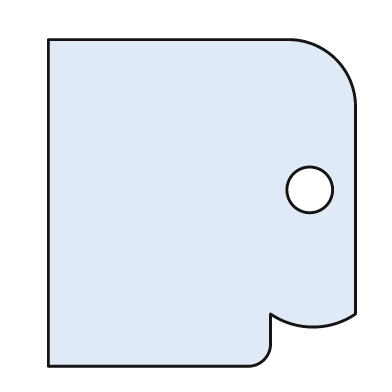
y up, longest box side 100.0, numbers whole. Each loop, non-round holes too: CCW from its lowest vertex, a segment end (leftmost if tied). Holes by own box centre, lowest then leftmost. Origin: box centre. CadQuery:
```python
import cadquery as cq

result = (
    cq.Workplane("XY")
    .moveTo(-47.0, -50.0)
    .lineTo(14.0, -50.0)
    .threePointArc((19.0, -48.0), (21.0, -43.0))
    .lineTo(21.0, -34.0)
    .threePointArc((34.0, -38.0), (47.0, -34.0))
    .lineTo(47.0, 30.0)
    .threePointArc((41.0, 44.0), (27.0, 50.0))
    .lineTo(-47.0, 50.0)
    .close()
    .moveTo(33.0, 4.0)
    .circle(7.0)
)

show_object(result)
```